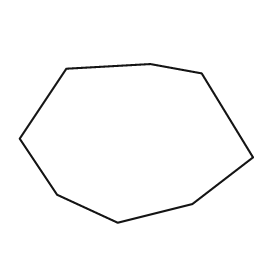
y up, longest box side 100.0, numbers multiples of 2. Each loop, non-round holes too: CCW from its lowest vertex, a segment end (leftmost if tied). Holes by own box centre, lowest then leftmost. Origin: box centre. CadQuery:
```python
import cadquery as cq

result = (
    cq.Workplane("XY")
    .moveTo(-8.0, -34.0)
    .lineTo(24.0, -26.0)
    .lineTo(50.0, -6.0)
    .lineTo(28.0, 30.0)
    .lineTo(6.0, 34.0)
    .lineTo(-30.0, 32.0)
    .lineTo(-50.0, 2.0)
    .lineTo(-34.0, -22.0)
    .close()
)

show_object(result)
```